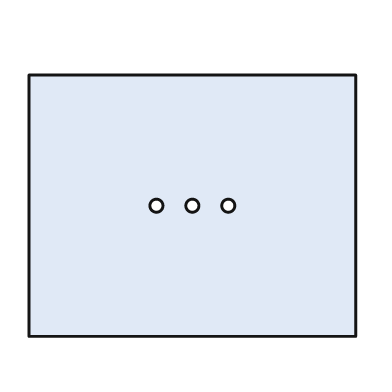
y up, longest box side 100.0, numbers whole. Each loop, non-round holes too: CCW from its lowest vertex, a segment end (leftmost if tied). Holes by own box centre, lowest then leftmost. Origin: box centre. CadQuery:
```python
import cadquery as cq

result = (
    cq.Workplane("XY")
    .moveTo(-50.0, -40.0)
    .lineTo(50.0, -40.0)
    .lineTo(50.0, 40.0)
    .lineTo(-50.0, 40.0)
    .close()
    .moveTo(-11.0, 0.0)
    .circle(2.0)
    .moveTo(0.0, 0.0)
    .circle(2.0)
    .moveTo(11.0, 0.0)
    .circle(2.0)
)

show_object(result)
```